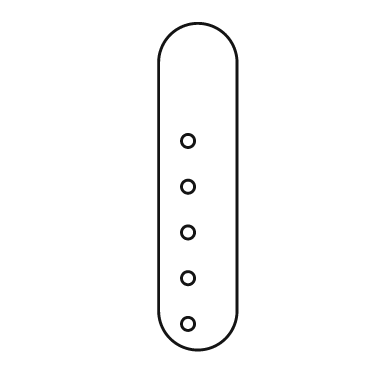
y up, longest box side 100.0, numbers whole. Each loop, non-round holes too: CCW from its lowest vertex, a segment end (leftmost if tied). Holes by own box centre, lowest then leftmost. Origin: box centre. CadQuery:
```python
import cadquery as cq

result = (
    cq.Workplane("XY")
    .moveTo(-12.0, -38.0)
    .threePointArc((0.0, -50.0), (12.0, -38.0))
    .lineTo(12.0, 38.0)
    .threePointArc((0.0, 50.0), (-12.0, 38.0))
    .close()
    .moveTo(-3.0, -42.0)
    .circle(2.0)
    .moveTo(-3.0, -28.0)
    .circle(2.0)
    .moveTo(-3.0, -14.0)
    .circle(2.0)
    .moveTo(-3.0, 0.0)
    .circle(2.0)
    .moveTo(-3.0, 14.0)
    .circle(2.0)
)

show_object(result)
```